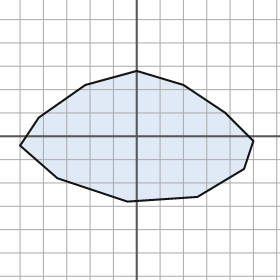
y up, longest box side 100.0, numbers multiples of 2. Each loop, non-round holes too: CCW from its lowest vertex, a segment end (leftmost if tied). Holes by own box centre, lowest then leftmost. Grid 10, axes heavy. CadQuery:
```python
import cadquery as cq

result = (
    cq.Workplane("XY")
    .moveTo(-4.0, -28.0)
    .lineTo(26.0, -26.0)
    .lineTo(46.0, -14.0)
    .lineTo(50.0, -2.0)
    .lineTo(38.0, 10.0)
    .lineTo(20.0, 22.0)
    .lineTo(0.0, 28.0)
    .lineTo(-22.0, 22.0)
    .lineTo(-42.0, 8.0)
    .lineTo(-50.0, -4.0)
    .lineTo(-34.0, -18.0)
    .close()
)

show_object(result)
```